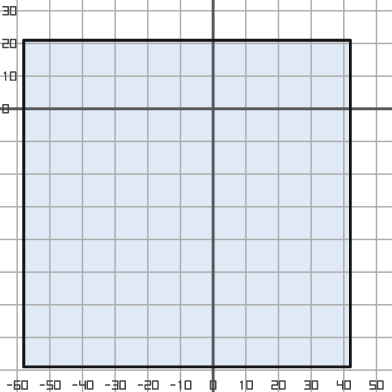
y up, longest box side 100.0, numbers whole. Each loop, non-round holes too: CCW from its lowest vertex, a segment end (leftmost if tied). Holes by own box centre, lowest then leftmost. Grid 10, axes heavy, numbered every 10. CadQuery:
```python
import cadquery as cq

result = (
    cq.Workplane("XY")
    .moveTo(-58.0, -79.0)
    .lineTo(42.0, -79.0)
    .lineTo(42.0, 21.0)
    .lineTo(-58.0, 21.0)
    .close()
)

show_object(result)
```